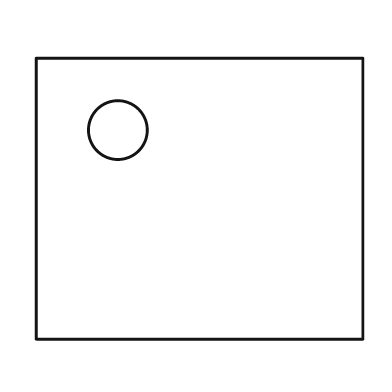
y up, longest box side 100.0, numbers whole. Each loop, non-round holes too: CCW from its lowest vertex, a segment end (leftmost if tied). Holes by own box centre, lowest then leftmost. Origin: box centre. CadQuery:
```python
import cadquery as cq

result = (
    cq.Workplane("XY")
    .moveTo(-50.0, -43.0)
    .lineTo(50.0, -43.0)
    .lineTo(50.0, 43.0)
    .lineTo(-50.0, 43.0)
    .close()
    .moveTo(-25.0, 21.0)
    .circle(9.0)
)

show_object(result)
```